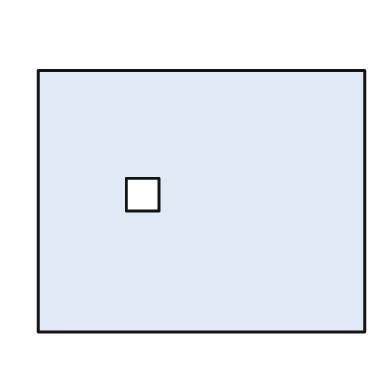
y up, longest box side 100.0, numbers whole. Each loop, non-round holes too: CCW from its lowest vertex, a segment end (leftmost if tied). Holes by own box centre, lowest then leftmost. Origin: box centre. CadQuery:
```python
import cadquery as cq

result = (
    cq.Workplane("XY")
    .moveTo(-50.0, -40.0)
    .lineTo(50.0, -40.0)
    .lineTo(50.0, 40.0)
    .lineTo(-50.0, 40.0)
    .close()
    .moveTo(-23.0, -3.0)
    .lineTo(-13.0, -3.0)
    .lineTo(-13.0, 7.0)
    .lineTo(-23.0, 7.0)
    .close()
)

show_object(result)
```